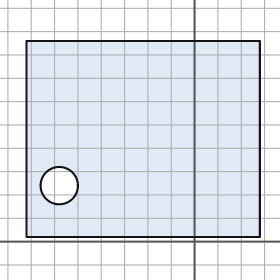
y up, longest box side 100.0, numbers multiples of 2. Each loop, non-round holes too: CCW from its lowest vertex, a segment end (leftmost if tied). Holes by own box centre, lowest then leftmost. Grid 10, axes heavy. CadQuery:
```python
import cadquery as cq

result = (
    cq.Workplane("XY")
    .moveTo(-72.0, 2.0)
    .lineTo(28.0, 2.0)
    .lineTo(28.0, 86.0)
    .lineTo(-72.0, 86.0)
    .close()
    .moveTo(-58.0, 24.0)
    .circle(8.0)
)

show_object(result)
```